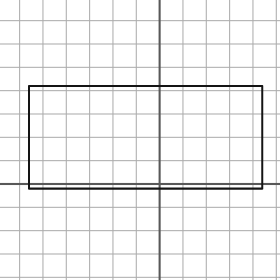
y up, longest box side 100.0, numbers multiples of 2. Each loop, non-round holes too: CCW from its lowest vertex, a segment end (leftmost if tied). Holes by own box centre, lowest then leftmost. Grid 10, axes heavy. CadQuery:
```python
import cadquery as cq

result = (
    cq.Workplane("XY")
    .moveTo(-56.0, -2.0)
    .lineTo(44.0, -2.0)
    .lineTo(44.0, 42.0)
    .lineTo(-56.0, 42.0)
    .close()
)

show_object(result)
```